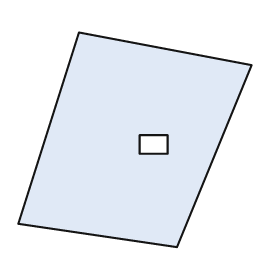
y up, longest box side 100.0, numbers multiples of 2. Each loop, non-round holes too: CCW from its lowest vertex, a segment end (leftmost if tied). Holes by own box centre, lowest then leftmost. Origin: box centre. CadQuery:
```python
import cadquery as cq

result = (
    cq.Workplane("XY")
    .moveTo(18.0, -46.0)
    .lineTo(50.0, 32.0)
    .lineTo(-24.0, 46.0)
    .lineTo(-50.0, -36.0)
    .close()
    .moveTo(2.0, -6.0)
    .lineTo(14.0, -6.0)
    .lineTo(14.0, 2.0)
    .lineTo(2.0, 2.0)
    .close()
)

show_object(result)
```